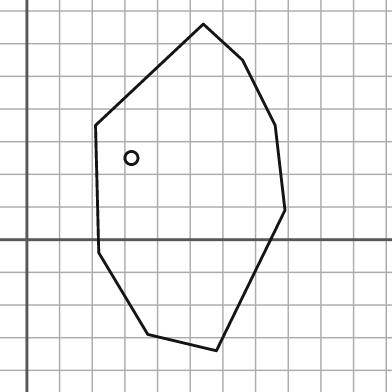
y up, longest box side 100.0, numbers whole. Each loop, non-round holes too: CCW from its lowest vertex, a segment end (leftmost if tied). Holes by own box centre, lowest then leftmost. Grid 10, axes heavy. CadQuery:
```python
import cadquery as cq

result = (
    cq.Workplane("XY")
    .moveTo(58.0, -34.0)
    .lineTo(79.0, 9.0)
    .lineTo(76.0, 35.0)
    .lineTo(66.0, 55.0)
    .lineTo(54.0, 66.0)
    .lineTo(21.0, 35.0)
    .lineTo(22.0, -4.0)
    .lineTo(37.0, -29.0)
    .close()
    .moveTo(32.0, 25.0)
    .circle(2.0)
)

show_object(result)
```